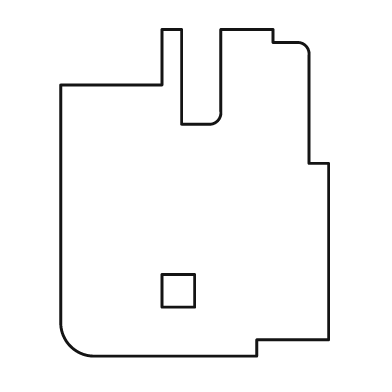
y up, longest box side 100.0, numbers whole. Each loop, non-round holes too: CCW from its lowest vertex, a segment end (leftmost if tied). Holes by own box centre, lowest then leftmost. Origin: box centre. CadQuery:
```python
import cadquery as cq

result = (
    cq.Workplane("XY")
    .moveTo(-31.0, -50.0)
    .lineTo(19.0, -50.0)
    .lineTo(19.0, -45.0)
    .lineTo(41.0, -45.0)
    .lineTo(41.0, 9.0)
    .lineTo(35.0, 9.0)
    .lineTo(35.0, 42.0)
    .threePointArc((34.0, 45.0), (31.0, 46.0))
    .lineTo(24.0, 46.0)
    .lineTo(24.0, 50.0)
    .lineTo(8.0, 50.0)
    .lineTo(8.0, 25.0)
    .threePointArc((7.0, 22.0), (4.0, 21.0))
    .lineTo(-4.0, 21.0)
    .lineTo(-4.0, 50.0)
    .lineTo(-10.0, 50.0)
    .lineTo(-10.0, 33.0)
    .lineTo(-41.0, 33.0)
    .lineTo(-41.0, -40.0)
    .threePointArc((-38.0, -47.0), (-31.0, -50.0))
    .close()
    .moveTo(-10.0, -35.0)
    .lineTo(0.0, -35.0)
    .lineTo(0.0, -25.0)
    .lineTo(-10.0, -25.0)
    .close()
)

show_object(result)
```